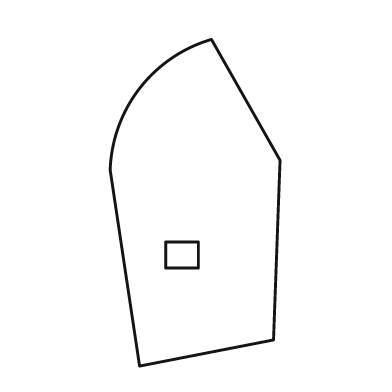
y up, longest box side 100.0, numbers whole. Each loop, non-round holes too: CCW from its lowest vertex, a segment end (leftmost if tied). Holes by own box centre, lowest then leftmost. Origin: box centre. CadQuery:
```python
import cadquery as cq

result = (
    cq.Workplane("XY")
    .moveTo(-17.0, -50.0)
    .lineTo(24.0, -42.0)
    .lineTo(26.0, 13.0)
    .lineTo(5.0, 50.0)
    .threePointArc((-17.0, 35.0), (-26.0, 10.0))
    .close()
    .moveTo(-9.0, -20.0)
    .lineTo(1.0, -20.0)
    .lineTo(1.0, -12.0)
    .lineTo(-9.0, -12.0)
    .close()
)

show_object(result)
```